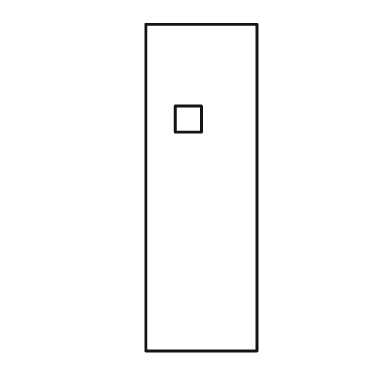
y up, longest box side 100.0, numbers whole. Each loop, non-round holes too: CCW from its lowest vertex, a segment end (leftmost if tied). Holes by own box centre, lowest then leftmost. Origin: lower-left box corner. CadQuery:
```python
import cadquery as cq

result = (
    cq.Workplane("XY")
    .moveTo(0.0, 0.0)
    .lineTo(34.0, 0.0)
    .lineTo(34.0, 100.0)
    .lineTo(0.0, 100.0)
    .close()
    .moveTo(9.0, 67.0)
    .lineTo(17.0, 67.0)
    .lineTo(17.0, 75.0)
    .lineTo(9.0, 75.0)
    .close()
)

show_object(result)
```